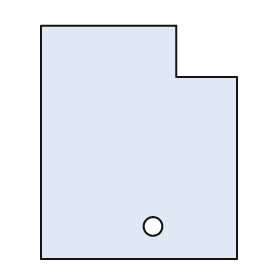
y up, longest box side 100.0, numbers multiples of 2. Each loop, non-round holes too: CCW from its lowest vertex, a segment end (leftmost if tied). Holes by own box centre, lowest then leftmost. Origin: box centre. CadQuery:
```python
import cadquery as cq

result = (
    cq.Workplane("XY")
    .moveTo(-42.0, -50.0)
    .lineTo(42.0, -50.0)
    .lineTo(42.0, 28.0)
    .lineTo(16.0, 28.0)
    .lineTo(16.0, 50.0)
    .lineTo(-42.0, 50.0)
    .close()
    .moveTo(6.0, -36.0)
    .circle(4.0)
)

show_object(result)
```